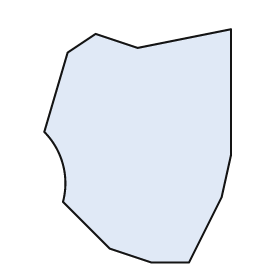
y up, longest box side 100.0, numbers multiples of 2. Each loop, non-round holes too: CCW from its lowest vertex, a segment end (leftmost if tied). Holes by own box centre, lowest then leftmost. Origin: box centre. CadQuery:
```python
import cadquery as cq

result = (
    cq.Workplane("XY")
    .moveTo(6.0, -50.0)
    .lineTo(22.0, -50.0)
    .lineTo(36.0, -22.0)
    .lineTo(40.0, -4.0)
    .lineTo(40.0, 50.0)
    .lineTo(0.0, 42.0)
    .lineTo(-18.0, 48.0)
    .lineTo(-30.0, 40.0)
    .lineTo(-40.0, 6.0)
    .threePointArc((-32.0, -8.0), (-32.0, -24.0))
    .lineTo(-12.0, -44.0)
    .close()
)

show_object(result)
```